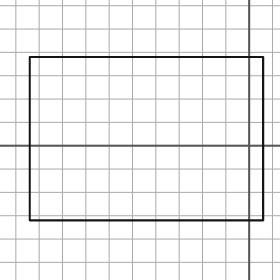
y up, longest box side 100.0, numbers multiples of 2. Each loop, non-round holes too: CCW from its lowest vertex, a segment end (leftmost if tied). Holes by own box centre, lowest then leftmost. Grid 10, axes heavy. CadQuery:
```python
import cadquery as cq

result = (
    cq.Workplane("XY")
    .moveTo(-94.0, -32.0)
    .lineTo(6.0, -32.0)
    .lineTo(6.0, 38.0)
    .lineTo(-94.0, 38.0)
    .close()
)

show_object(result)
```